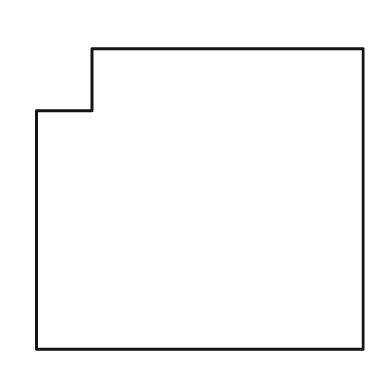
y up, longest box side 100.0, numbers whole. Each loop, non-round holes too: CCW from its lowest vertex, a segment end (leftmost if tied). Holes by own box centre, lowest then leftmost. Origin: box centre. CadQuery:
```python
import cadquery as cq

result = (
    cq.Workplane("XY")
    .moveTo(-50.0, -46.0)
    .lineTo(50.0, -46.0)
    .lineTo(50.0, 46.0)
    .lineTo(-33.0, 46.0)
    .lineTo(-33.0, 27.0)
    .lineTo(-50.0, 27.0)
    .close()
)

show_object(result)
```